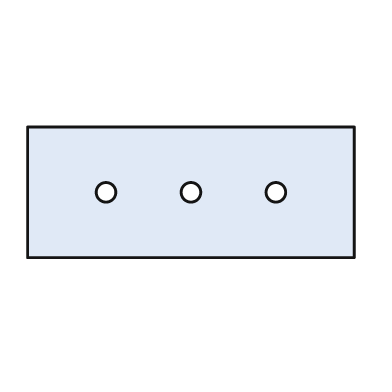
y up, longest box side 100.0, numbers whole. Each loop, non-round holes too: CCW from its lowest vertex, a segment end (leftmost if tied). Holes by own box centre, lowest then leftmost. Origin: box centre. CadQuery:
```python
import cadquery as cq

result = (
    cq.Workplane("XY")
    .moveTo(-50.0, -20.0)
    .lineTo(50.0, -20.0)
    .lineTo(50.0, 20.0)
    .lineTo(-50.0, 20.0)
    .close()
    .moveTo(-26.0, 0.0)
    .circle(3.0)
    .moveTo(0.0, 0.0)
    .circle(3.0)
    .moveTo(26.0, 0.0)
    .circle(3.0)
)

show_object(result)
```